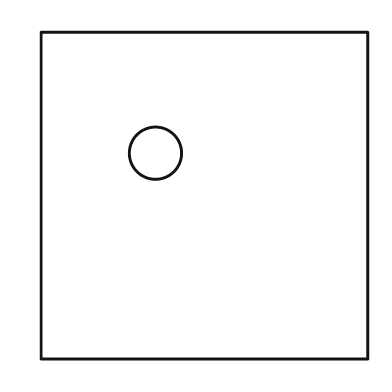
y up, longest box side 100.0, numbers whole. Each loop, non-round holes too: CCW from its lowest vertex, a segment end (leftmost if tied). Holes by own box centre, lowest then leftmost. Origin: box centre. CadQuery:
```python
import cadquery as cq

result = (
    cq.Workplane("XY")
    .moveTo(-50.0, -50.0)
    .lineTo(50.0, -50.0)
    .lineTo(50.0, 50.0)
    .lineTo(-50.0, 50.0)
    .close()
    .moveTo(-15.0, 13.0)
    .circle(8.0)
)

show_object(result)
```